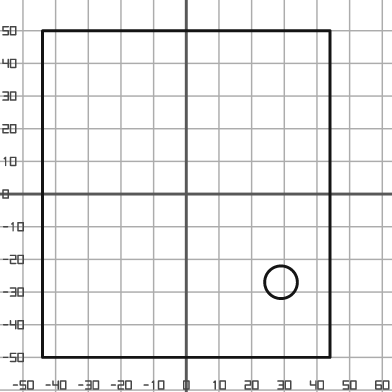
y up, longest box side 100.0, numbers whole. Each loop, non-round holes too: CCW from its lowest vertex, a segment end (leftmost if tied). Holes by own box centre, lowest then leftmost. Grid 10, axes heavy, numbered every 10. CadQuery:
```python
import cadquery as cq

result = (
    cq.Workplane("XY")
    .moveTo(-44.0, -50.0)
    .lineTo(44.0, -50.0)
    .lineTo(44.0, 50.0)
    .lineTo(-44.0, 50.0)
    .close()
    .moveTo(29.0, -27.0)
    .circle(5.0)
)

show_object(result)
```